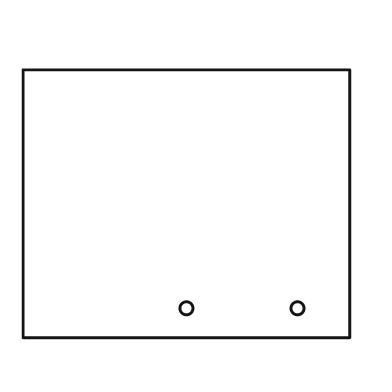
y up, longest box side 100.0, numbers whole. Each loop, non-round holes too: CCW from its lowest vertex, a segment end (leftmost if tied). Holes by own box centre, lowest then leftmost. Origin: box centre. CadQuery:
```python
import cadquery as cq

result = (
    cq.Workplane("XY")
    .moveTo(-50.0, -41.0)
    .lineTo(50.0, -41.0)
    .lineTo(50.0, 41.0)
    .lineTo(-50.0, 41.0)
    .close()
    .moveTo(0.0, -32.0)
    .circle(2.0)
    .moveTo(34.0, -32.0)
    .circle(2.0)
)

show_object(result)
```